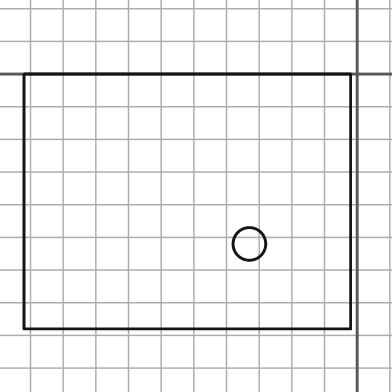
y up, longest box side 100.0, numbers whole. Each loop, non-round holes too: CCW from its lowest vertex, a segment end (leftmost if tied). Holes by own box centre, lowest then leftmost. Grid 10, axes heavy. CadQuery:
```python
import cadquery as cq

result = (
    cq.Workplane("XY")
    .moveTo(-102.0, -78.0)
    .lineTo(-2.0, -78.0)
    .lineTo(-2.0, 0.0)
    .lineTo(-102.0, 0.0)
    .close()
    .moveTo(-33.0, -52.0)
    .circle(5.0)
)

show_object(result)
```